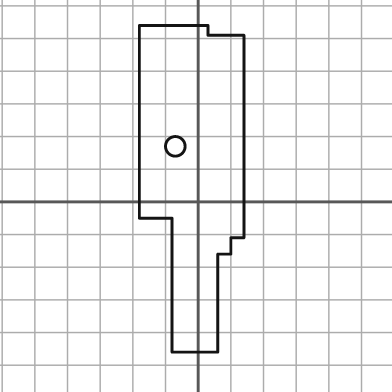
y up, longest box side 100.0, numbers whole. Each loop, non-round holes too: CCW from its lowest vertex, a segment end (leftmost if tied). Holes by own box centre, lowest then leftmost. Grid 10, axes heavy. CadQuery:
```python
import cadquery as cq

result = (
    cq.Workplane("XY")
    .moveTo(-8.0, -46.0)
    .lineTo(6.0, -46.0)
    .lineTo(6.0, -16.0)
    .lineTo(10.0, -16.0)
    .lineTo(10.0, -11.0)
    .lineTo(14.0, -11.0)
    .lineTo(14.0, 51.0)
    .lineTo(3.0, 51.0)
    .lineTo(3.0, 54.0)
    .lineTo(-18.0, 54.0)
    .lineTo(-18.0, -5.0)
    .lineTo(-8.0, -5.0)
    .close()
    .moveTo(-7.0, 17.0)
    .circle(3.0)
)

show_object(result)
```